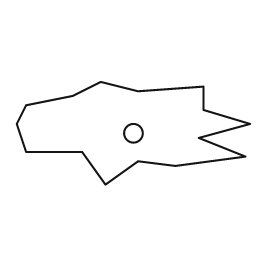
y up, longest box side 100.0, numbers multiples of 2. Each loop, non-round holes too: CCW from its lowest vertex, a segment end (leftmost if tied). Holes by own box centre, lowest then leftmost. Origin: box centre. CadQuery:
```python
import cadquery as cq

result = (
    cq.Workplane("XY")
    .moveTo(-12.0, -22.0)
    .lineTo(2.0, -12.0)
    .lineTo(18.0, -14.0)
    .lineTo(48.0, -10.0)
    .lineTo(28.0, -2.0)
    .lineTo(50.0, 4.0)
    .lineTo(30.0, 10.0)
    .lineTo(30.0, 20.0)
    .lineTo(2.0, 18.0)
    .lineTo(-14.0, 22.0)
    .lineTo(-26.0, 16.0)
    .lineTo(-46.0, 12.0)
    .lineTo(-50.0, 4.0)
    .lineTo(-46.0, -8.0)
    .lineTo(-22.0, -8.0)
    .close()
    .moveTo(0.0, 0.0)
    .circle(4.0)
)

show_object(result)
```